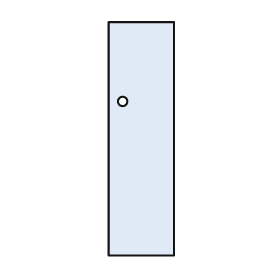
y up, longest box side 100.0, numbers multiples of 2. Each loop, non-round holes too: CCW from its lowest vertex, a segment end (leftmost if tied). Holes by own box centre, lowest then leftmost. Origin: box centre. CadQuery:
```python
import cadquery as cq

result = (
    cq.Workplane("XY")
    .moveTo(-14.0, -50.0)
    .lineTo(14.0, -50.0)
    .lineTo(14.0, 50.0)
    .lineTo(-14.0, 50.0)
    .close()
    .moveTo(-8.0, 16.0)
    .circle(2.0)
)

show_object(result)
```